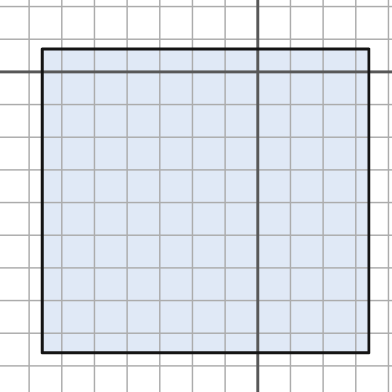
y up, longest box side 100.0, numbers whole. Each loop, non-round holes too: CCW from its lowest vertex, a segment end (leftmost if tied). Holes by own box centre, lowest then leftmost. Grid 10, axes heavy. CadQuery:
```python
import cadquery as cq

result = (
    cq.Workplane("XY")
    .moveTo(-66.0, -86.0)
    .lineTo(34.0, -86.0)
    .lineTo(34.0, 7.0)
    .lineTo(-66.0, 7.0)
    .close()
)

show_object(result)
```